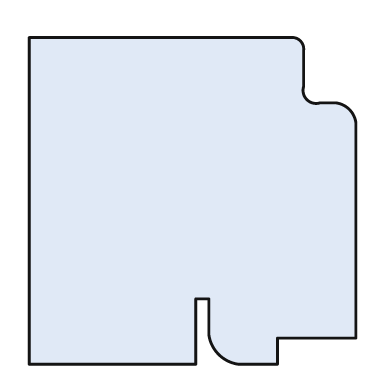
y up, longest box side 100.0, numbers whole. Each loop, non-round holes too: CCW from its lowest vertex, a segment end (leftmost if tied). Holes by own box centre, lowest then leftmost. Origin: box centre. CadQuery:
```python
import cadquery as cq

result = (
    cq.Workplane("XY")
    .moveTo(-50.0, -50.0)
    .lineTo(1.0, -50.0)
    .lineTo(1.0, -30.0)
    .lineTo(5.0, -30.0)
    .lineTo(5.0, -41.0)
    .threePointArc((8.0, -47.0), (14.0, -50.0))
    .lineTo(26.0, -50.0)
    .lineTo(26.0, -42.0)
    .lineTo(50.0, -42.0)
    .lineTo(50.0, 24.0)
    .threePointArc((48.0, 28.0), (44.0, 30.0))
    .lineTo(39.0, 30.0)
    .threePointArc((35.0, 31.0), (34.0, 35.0))
    .lineTo(34.0, 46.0)
    .threePointArc((33.0, 49.0), (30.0, 50.0))
    .lineTo(-50.0, 50.0)
    .close()
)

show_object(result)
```